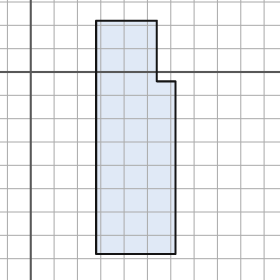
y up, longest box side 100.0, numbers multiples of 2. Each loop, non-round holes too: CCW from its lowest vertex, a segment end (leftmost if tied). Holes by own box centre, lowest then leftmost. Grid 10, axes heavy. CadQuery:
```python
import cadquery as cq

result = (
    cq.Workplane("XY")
    .moveTo(28.0, -78.0)
    .lineTo(62.0, -78.0)
    .lineTo(62.0, -4.0)
    .lineTo(54.0, -4.0)
    .lineTo(54.0, 22.0)
    .lineTo(28.0, 22.0)
    .close()
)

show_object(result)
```